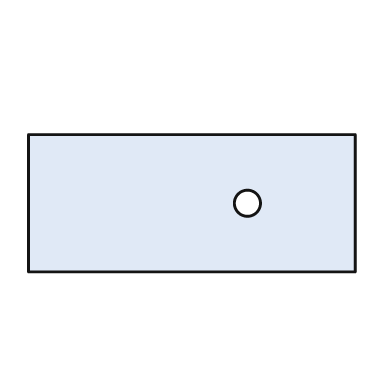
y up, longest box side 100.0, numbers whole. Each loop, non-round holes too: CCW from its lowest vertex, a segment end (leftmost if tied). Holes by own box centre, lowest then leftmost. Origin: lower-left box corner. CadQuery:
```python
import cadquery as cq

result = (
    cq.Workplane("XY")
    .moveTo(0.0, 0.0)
    .lineTo(100.0, 0.0)
    .lineTo(100.0, 42.0)
    .lineTo(0.0, 42.0)
    .close()
    .moveTo(67.0, 21.0)
    .circle(4.0)
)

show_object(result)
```